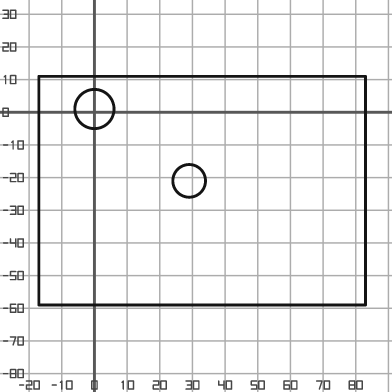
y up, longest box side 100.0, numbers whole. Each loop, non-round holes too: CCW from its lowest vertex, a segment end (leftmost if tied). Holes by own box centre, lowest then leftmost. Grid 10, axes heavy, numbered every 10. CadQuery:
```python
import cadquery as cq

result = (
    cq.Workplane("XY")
    .moveTo(-17.0, -59.0)
    .lineTo(83.0, -59.0)
    .lineTo(83.0, 11.0)
    .lineTo(-17.0, 11.0)
    .close()
    .moveTo(29.0, -21.0)
    .circle(5.0)
    .moveTo(0.0, 1.0)
    .circle(6.0)
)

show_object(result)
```